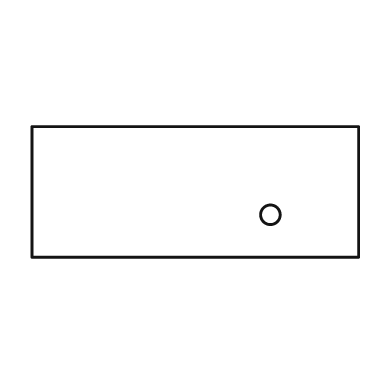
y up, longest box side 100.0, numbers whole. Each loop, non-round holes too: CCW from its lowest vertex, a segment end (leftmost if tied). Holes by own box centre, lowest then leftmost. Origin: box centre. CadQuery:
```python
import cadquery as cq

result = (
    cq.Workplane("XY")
    .moveTo(-50.0, -20.0)
    .lineTo(50.0, -20.0)
    .lineTo(50.0, 20.0)
    .lineTo(-50.0, 20.0)
    .close()
    .moveTo(23.0, -7.0)
    .circle(3.0)
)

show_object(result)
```